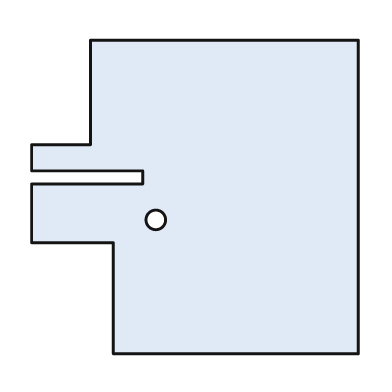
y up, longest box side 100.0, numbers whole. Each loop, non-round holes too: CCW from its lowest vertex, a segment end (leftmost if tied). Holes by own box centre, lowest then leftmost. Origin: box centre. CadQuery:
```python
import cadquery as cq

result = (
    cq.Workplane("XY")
    .moveTo(-25.0, -48.0)
    .lineTo(50.0, -48.0)
    .lineTo(50.0, 48.0)
    .lineTo(-32.0, 48.0)
    .lineTo(-32.0, 16.0)
    .lineTo(-50.0, 16.0)
    .lineTo(-50.0, 8.0)
    .lineTo(-16.0, 8.0)
    .lineTo(-16.0, 4.0)
    .lineTo(-50.0, 4.0)
    .lineTo(-50.0, -14.0)
    .lineTo(-25.0, -14.0)
    .close()
    .moveTo(-12.0, -7.0)
    .circle(3.0)
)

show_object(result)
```